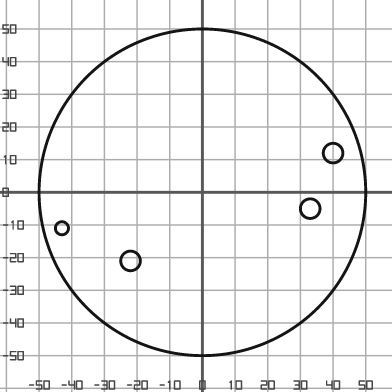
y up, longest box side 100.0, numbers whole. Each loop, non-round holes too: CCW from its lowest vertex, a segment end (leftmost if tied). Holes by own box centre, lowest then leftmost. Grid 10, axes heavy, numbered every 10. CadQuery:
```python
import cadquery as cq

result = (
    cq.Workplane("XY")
    .moveTo(0.0, 0.0)
    .circle(50.0)
    .moveTo(-22.0, -21.0)
    .circle(3.0)
    .moveTo(-43.0, -11.0)
    .circle(2.0)
    .moveTo(33.0, -5.0)
    .circle(3.0)
    .moveTo(40.0, 12.0)
    .circle(3.0)
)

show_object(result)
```